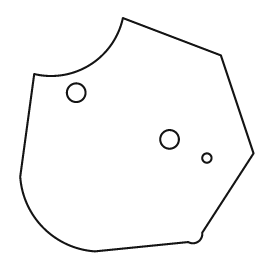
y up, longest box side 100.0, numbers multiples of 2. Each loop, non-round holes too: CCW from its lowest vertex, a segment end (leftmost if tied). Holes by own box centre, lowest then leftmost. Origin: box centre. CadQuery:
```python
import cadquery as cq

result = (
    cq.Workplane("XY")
    .moveTo(-18.0, -50.0)
    .lineTo(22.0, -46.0)
    .threePointArc((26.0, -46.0), (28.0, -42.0))
    .lineTo(50.0, -8.0)
    .lineTo(36.0, 34.0)
    .lineTo(-6.0, 50.0)
    .threePointArc((-20.0, 30.0), (-44.0, 26.0))
    .lineTo(-50.0, -18.0)
    .threePointArc((-40.0, -40.0), (-18.0, -50.0))
    .close()
    .moveTo(30.0, -10.0)
    .circle(2.0)
    .moveTo(14.0, -2.0)
    .circle(4.0)
    .moveTo(-26.0, 18.0)
    .circle(4.0)
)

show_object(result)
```